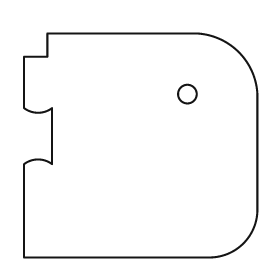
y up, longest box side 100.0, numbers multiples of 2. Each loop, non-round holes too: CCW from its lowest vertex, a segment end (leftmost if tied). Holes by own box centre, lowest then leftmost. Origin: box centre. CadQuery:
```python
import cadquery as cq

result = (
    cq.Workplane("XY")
    .moveTo(-50.0, -48.0)
    .lineTo(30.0, -48.0)
    .threePointArc((44.0, -42.0), (50.0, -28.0))
    .lineTo(50.0, 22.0)
    .threePointArc((42.0, 40.0), (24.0, 48.0))
    .lineTo(-40.0, 48.0)
    .lineTo(-40.0, 38.0)
    .lineTo(-50.0, 38.0)
    .lineTo(-50.0, 16.0)
    .threePointArc((-44.0, 14.0), (-38.0, 16.0))
    .lineTo(-38.0, -8.0)
    .threePointArc((-44.0, -6.0), (-50.0, -8.0))
    .close()
    .moveTo(20.0, 22.0)
    .circle(4.0)
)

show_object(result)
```